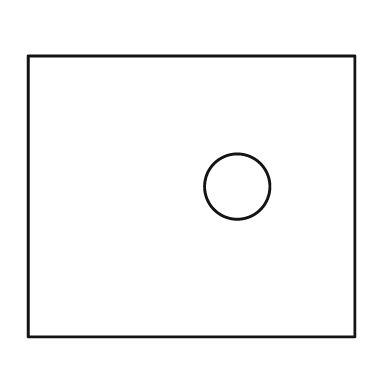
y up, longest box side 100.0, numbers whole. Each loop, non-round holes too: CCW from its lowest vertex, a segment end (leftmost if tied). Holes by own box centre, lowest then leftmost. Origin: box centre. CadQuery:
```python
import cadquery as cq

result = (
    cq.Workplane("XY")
    .moveTo(-50.0, -43.0)
    .lineTo(50.0, -43.0)
    .lineTo(50.0, 43.0)
    .lineTo(-50.0, 43.0)
    .close()
    .moveTo(14.0, 3.0)
    .circle(10.0)
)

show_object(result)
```